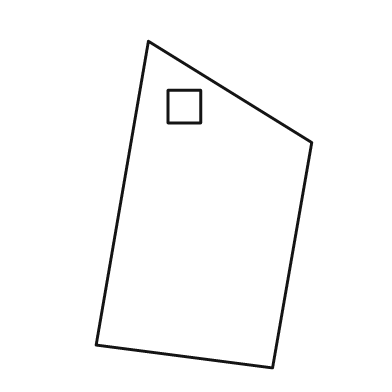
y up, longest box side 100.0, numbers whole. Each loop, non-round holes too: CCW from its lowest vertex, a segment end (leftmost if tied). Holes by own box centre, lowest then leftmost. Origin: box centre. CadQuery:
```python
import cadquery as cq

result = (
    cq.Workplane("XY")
    .moveTo(21.0, -50.0)
    .lineTo(33.0, 19.0)
    .lineTo(-17.0, 50.0)
    .lineTo(-33.0, -43.0)
    .close()
    .moveTo(-11.0, 25.0)
    .lineTo(-1.0, 25.0)
    .lineTo(-1.0, 35.0)
    .lineTo(-11.0, 35.0)
    .close()
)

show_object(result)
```